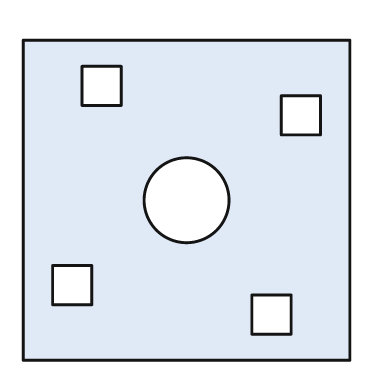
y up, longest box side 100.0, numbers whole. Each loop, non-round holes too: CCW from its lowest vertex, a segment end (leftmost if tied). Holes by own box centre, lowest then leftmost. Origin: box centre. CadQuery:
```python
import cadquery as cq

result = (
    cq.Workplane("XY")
    .moveTo(-50.0, -49.0)
    .lineTo(50.0, -49.0)
    .lineTo(50.0, 49.0)
    .lineTo(-50.0, 49.0)
    .close()
    .moveTo(20.0, -41.0)
    .lineTo(32.0, -41.0)
    .lineTo(32.0, -29.0)
    .lineTo(20.0, -29.0)
    .close()
    .moveTo(-41.0, -32.0)
    .lineTo(-29.0, -32.0)
    .lineTo(-29.0, -20.0)
    .lineTo(-41.0, -20.0)
    .close()
    .moveTo(0.0, 0.0)
    .circle(13.0)
    .moveTo(29.0, 20.0)
    .lineTo(41.0, 20.0)
    .lineTo(41.0, 32.0)
    .lineTo(29.0, 32.0)
    .close()
    .moveTo(-32.0, 29.0)
    .lineTo(-20.0, 29.0)
    .lineTo(-20.0, 41.0)
    .lineTo(-32.0, 41.0)
    .close()
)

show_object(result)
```